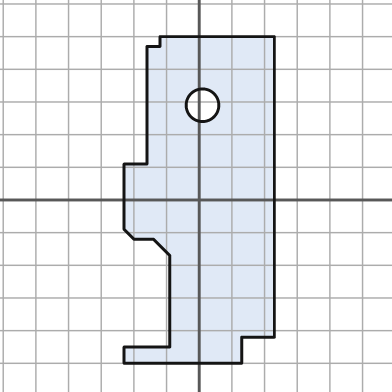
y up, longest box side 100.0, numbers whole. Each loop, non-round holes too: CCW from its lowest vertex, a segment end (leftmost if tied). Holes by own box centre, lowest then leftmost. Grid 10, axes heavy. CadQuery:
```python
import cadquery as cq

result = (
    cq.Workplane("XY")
    .moveTo(-23.0, -50.0)
    .lineTo(13.0, -50.0)
    .lineTo(13.0, -42.0)
    .lineTo(23.0, -42.0)
    .lineTo(23.0, 50.0)
    .lineTo(-12.0, 50.0)
    .lineTo(-12.0, 47.0)
    .lineTo(-16.0, 47.0)
    .lineTo(-16.0, 11.0)
    .lineTo(-23.0, 11.0)
    .lineTo(-23.0, -9.0)
    .lineTo(-20.0, -12.0)
    .lineTo(-14.0, -12.0)
    .lineTo(-9.0, -17.0)
    .lineTo(-9.0, -45.0)
    .lineTo(-23.0, -45.0)
    .close()
    .moveTo(1.0, 29.0)
    .circle(5.0)
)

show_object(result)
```